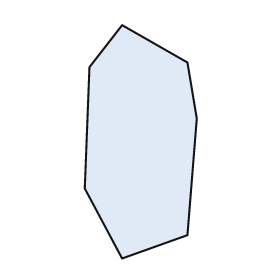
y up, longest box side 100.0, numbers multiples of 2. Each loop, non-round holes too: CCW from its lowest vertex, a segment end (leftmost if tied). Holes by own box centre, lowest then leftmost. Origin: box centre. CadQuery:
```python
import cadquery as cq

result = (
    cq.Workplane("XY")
    .moveTo(-8.0, -50.0)
    .lineTo(20.0, -40.0)
    .lineTo(24.0, 10.0)
    .lineTo(20.0, 34.0)
    .lineTo(-8.0, 50.0)
    .lineTo(-22.0, 32.0)
    .lineTo(-24.0, -20.0)
    .close()
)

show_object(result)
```